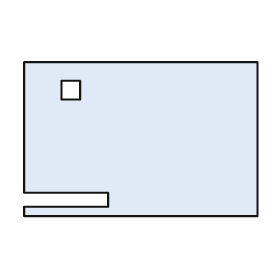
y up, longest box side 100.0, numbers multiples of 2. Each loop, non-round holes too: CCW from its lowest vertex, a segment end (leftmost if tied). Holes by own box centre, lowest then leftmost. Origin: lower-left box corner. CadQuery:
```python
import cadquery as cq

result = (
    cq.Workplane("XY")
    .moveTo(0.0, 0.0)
    .lineTo(100.0, 0.0)
    .lineTo(100.0, 66.0)
    .lineTo(0.0, 66.0)
    .lineTo(0.0, 10.0)
    .lineTo(36.0, 10.0)
    .lineTo(36.0, 4.0)
    .lineTo(0.0, 4.0)
    .close()
    .moveTo(16.0, 50.0)
    .lineTo(24.0, 50.0)
    .lineTo(24.0, 58.0)
    .lineTo(16.0, 58.0)
    .close()
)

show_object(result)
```